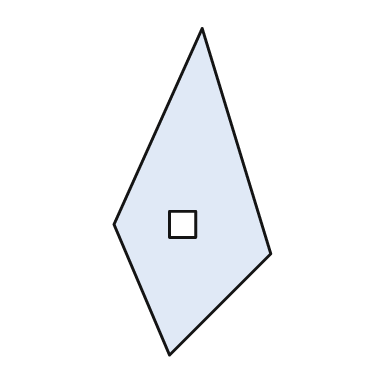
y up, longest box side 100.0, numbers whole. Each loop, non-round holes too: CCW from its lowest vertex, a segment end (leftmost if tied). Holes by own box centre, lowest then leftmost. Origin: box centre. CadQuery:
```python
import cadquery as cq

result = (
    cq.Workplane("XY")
    .moveTo(-7.0, -50.0)
    .lineTo(24.0, -19.0)
    .lineTo(3.0, 50.0)
    .lineTo(-24.0, -10.0)
    .close()
    .moveTo(-7.0, -14.0)
    .lineTo(1.0, -14.0)
    .lineTo(1.0, -6.0)
    .lineTo(-7.0, -6.0)
    .close()
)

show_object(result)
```